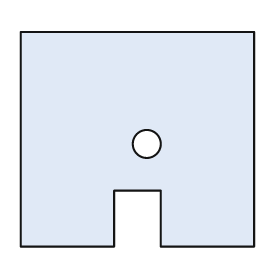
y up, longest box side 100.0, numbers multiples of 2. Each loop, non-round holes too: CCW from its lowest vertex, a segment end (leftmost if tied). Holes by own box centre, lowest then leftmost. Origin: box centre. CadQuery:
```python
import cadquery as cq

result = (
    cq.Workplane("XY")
    .moveTo(-50.0, -46.0)
    .lineTo(-10.0, -46.0)
    .lineTo(-10.0, -22.0)
    .lineTo(10.0, -22.0)
    .lineTo(10.0, -46.0)
    .lineTo(50.0, -46.0)
    .lineTo(50.0, 46.0)
    .lineTo(-50.0, 46.0)
    .close()
    .moveTo(4.0, -2.0)
    .circle(6.0)
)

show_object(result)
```